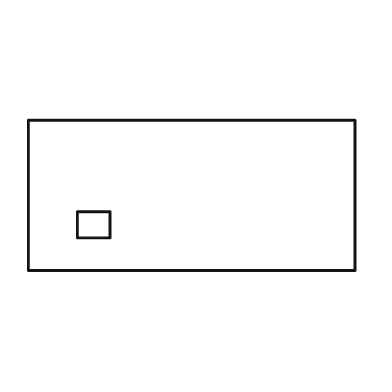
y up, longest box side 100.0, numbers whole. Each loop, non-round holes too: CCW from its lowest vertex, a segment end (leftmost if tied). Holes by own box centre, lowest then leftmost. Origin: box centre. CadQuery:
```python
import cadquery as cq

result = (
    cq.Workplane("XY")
    .moveTo(-50.0, -23.0)
    .lineTo(50.0, -23.0)
    .lineTo(50.0, 23.0)
    .lineTo(-50.0, 23.0)
    .close()
    .moveTo(-35.0, -13.0)
    .lineTo(-25.0, -13.0)
    .lineTo(-25.0, -5.0)
    .lineTo(-35.0, -5.0)
    .close()
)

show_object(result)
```